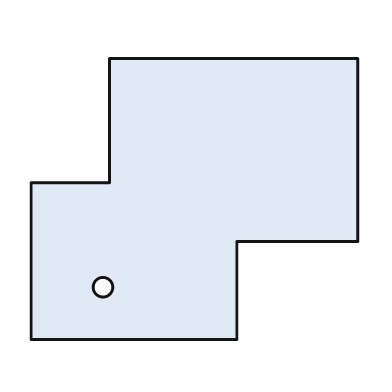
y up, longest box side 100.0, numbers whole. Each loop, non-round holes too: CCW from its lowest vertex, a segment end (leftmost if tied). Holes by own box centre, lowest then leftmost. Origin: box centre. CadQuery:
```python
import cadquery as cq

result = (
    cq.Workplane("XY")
    .moveTo(-50.0, -43.0)
    .lineTo(13.0, -43.0)
    .lineTo(13.0, -13.0)
    .lineTo(50.0, -13.0)
    .lineTo(50.0, 43.0)
    .lineTo(-26.0, 43.0)
    .lineTo(-26.0, 5.0)
    .lineTo(-50.0, 5.0)
    .close()
    .moveTo(-28.0, -27.0)
    .circle(3.0)
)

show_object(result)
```